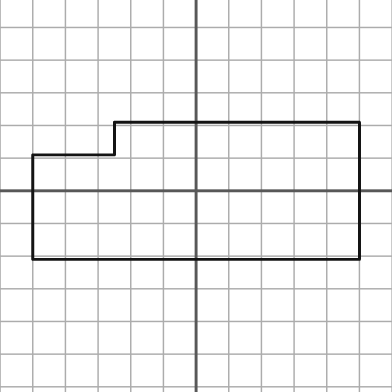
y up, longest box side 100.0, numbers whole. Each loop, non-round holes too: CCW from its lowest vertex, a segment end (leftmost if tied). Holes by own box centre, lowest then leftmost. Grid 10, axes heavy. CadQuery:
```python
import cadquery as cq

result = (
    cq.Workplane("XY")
    .moveTo(-50.0, -21.0)
    .lineTo(50.0, -21.0)
    .lineTo(50.0, 21.0)
    .lineTo(-25.0, 21.0)
    .lineTo(-25.0, 11.0)
    .lineTo(-50.0, 11.0)
    .close()
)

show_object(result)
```